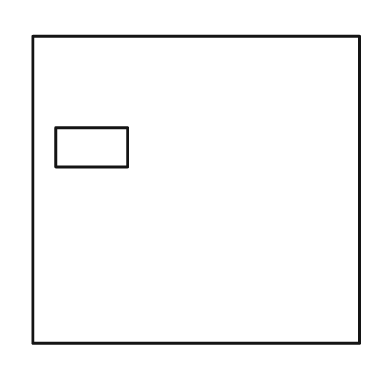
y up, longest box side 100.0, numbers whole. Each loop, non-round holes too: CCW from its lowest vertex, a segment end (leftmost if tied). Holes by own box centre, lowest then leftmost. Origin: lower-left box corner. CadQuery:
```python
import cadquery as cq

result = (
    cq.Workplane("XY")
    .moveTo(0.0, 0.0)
    .lineTo(100.0, 0.0)
    .lineTo(100.0, 94.0)
    .lineTo(0.0, 94.0)
    .close()
    .moveTo(7.0, 54.0)
    .lineTo(29.0, 54.0)
    .lineTo(29.0, 66.0)
    .lineTo(7.0, 66.0)
    .close()
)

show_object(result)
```